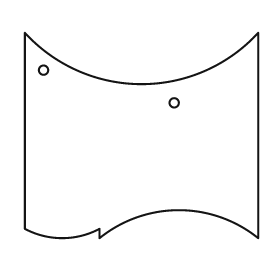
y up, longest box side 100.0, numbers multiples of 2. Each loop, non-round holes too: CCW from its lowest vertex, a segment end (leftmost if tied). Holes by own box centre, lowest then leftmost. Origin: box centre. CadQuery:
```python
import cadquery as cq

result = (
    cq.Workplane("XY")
    .moveTo(-18.0, -44.0)
    .threePointArc((16.0, -32.0), (50.0, -44.0))
    .lineTo(50.0, 44.0)
    .threePointArc((0.0, 22.0), (-50.0, 44.0))
    .lineTo(-50.0, -40.0)
    .threePointArc((-34.0, -44.0), (-18.0, -40.0))
    .close()
    .moveTo(14.0, 14.0)
    .circle(2.0)
    .moveTo(-42.0, 28.0)
    .circle(2.0)
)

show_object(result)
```